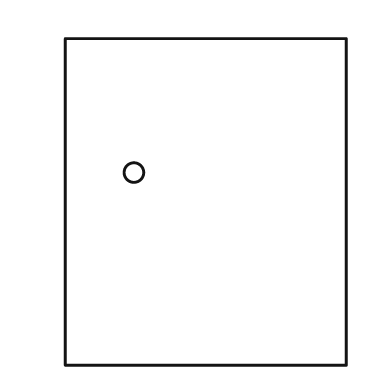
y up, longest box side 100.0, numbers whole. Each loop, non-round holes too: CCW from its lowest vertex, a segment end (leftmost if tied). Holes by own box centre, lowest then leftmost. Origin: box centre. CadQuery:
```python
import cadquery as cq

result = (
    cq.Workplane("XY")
    .moveTo(-43.0, -50.0)
    .lineTo(43.0, -50.0)
    .lineTo(43.0, 50.0)
    .lineTo(-43.0, 50.0)
    .close()
    .moveTo(-22.0, 9.0)
    .circle(3.0)
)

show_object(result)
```